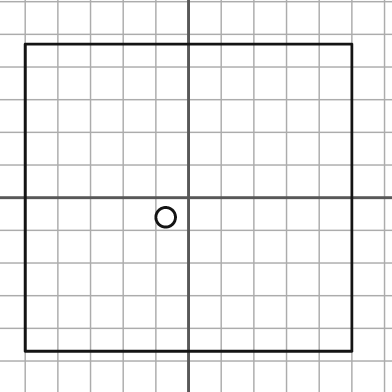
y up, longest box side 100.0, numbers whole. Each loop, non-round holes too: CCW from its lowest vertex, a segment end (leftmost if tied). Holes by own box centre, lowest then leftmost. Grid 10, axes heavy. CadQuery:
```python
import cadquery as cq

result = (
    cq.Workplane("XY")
    .moveTo(-50.0, -47.0)
    .lineTo(50.0, -47.0)
    .lineTo(50.0, 47.0)
    .lineTo(-50.0, 47.0)
    .close()
    .moveTo(-7.0, -6.0)
    .circle(3.0)
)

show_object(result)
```